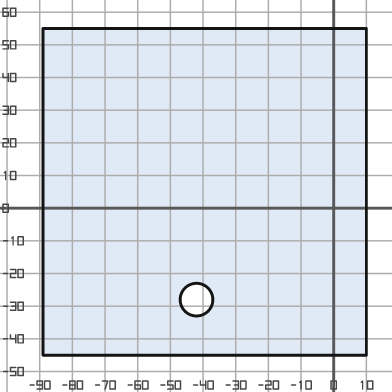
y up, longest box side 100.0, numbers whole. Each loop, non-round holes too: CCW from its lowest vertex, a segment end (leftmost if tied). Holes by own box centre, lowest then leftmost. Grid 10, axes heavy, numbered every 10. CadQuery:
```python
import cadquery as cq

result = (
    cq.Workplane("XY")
    .moveTo(-89.0, -45.0)
    .lineTo(10.0, -45.0)
    .lineTo(10.0, 55.0)
    .lineTo(-89.0, 55.0)
    .close()
    .moveTo(-42.0, -28.0)
    .circle(5.0)
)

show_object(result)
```